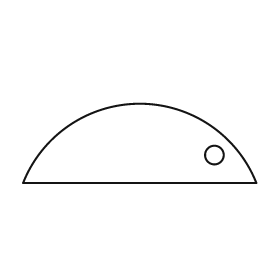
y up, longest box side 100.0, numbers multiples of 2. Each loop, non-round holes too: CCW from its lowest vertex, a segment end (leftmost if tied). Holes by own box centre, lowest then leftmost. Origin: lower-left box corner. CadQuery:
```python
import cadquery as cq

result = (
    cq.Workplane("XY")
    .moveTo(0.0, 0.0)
    .lineTo(100.0, 0.0)
    .threePointArc((50.0, 34.0), (0.0, 0.0))
    .close()
    .moveTo(82.0, 12.0)
    .circle(4.0)
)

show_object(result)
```